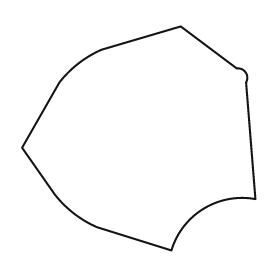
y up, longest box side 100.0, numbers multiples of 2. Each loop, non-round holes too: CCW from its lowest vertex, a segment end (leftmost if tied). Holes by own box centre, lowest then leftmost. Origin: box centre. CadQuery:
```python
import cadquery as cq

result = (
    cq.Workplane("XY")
    .moveTo(14.0, -48.0)
    .threePointArc((28.0, -30.0), (50.0, -26.0))
    .lineTo(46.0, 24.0)
    .threePointArc((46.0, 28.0), (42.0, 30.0))
    .lineTo(18.0, 48.0)
    .lineTo(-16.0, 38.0)
    .threePointArc((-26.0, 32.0), (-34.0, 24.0))
    .lineTo(-50.0, -4.0)
    .lineTo(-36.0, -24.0)
    .threePointArc((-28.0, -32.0), (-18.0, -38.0))
    .close()
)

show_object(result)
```